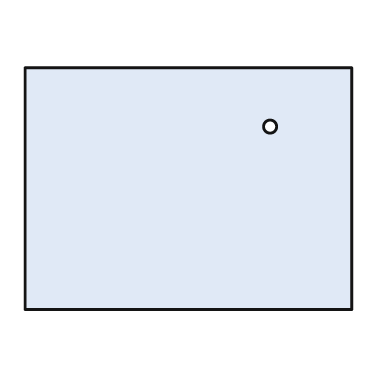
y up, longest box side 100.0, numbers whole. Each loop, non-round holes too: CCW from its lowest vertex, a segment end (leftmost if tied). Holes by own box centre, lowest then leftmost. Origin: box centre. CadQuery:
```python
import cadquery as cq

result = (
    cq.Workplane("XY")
    .moveTo(-50.0, -37.0)
    .lineTo(50.0, -37.0)
    .lineTo(50.0, 37.0)
    .lineTo(-50.0, 37.0)
    .close()
    .moveTo(25.0, 19.0)
    .circle(2.0)
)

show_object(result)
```